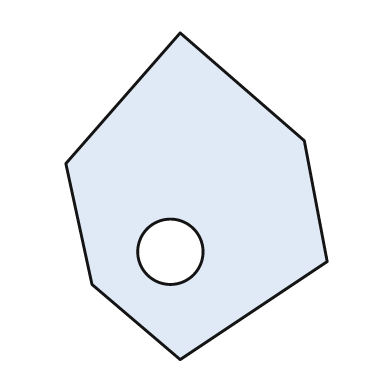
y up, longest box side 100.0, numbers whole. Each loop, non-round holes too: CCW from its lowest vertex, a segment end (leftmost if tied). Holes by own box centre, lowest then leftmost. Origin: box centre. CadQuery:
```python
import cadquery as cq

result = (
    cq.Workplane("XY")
    .moveTo(-5.0, -50.0)
    .lineTo(40.0, -20.0)
    .lineTo(33.0, 17.0)
    .lineTo(-5.0, 50.0)
    .lineTo(-40.0, 10.0)
    .lineTo(-32.0, -27.0)
    .close()
    .moveTo(-8.0, -17.0)
    .circle(10.0)
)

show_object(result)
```